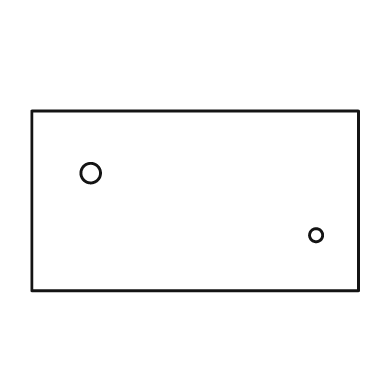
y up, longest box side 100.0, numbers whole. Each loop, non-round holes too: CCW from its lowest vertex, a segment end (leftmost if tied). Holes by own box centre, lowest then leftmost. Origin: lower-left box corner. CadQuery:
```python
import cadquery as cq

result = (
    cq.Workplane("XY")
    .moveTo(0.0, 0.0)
    .lineTo(100.0, 0.0)
    .lineTo(100.0, 55.0)
    .lineTo(0.0, 55.0)
    .close()
    .moveTo(87.0, 17.0)
    .circle(2.0)
    .moveTo(18.0, 36.0)
    .circle(3.0)
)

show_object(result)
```